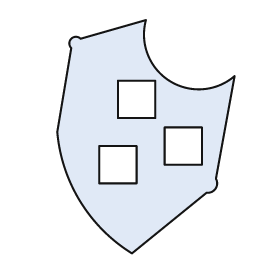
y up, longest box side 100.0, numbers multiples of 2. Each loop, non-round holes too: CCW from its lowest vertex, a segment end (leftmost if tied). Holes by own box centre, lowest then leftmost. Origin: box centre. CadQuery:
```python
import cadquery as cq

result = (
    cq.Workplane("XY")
    .moveTo(-6.0, -50.0)
    .lineTo(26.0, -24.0)
    .threePointArc((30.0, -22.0), (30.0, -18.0))
    .lineTo(38.0, 26.0)
    .threePointArc((10.0, 24.0), (0.0, 50.0))
    .lineTo(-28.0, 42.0)
    .threePointArc((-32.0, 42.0), (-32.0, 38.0))
    .lineTo(-38.0, 2.0)
    .threePointArc((-28.0, -28.0), (-6.0, -50.0))
    .close()
    .moveTo(-20.0, -20.0)
    .lineTo(-4.0, -20.0)
    .lineTo(-4.0, -4.0)
    .lineTo(-20.0, -4.0)
    .close()
    .moveTo(8.0, -12.0)
    .lineTo(24.0, -12.0)
    .lineTo(24.0, 4.0)
    .lineTo(8.0, 4.0)
    .close()
    .moveTo(-12.0, 8.0)
    .lineTo(4.0, 8.0)
    .lineTo(4.0, 24.0)
    .lineTo(-12.0, 24.0)
    .close()
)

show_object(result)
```